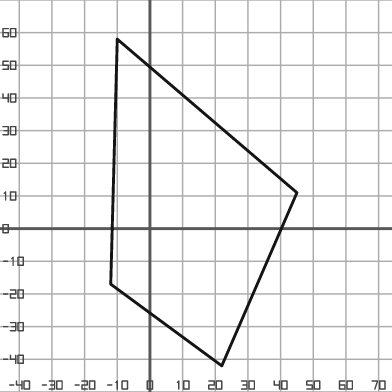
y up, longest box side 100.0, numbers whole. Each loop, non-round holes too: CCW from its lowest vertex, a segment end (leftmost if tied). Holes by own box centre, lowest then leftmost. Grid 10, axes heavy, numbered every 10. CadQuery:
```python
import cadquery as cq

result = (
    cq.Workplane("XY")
    .moveTo(22.0, -42.0)
    .lineTo(45.0, 11.0)
    .lineTo(-10.0, 58.0)
    .lineTo(-12.0, -17.0)
    .close()
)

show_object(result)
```